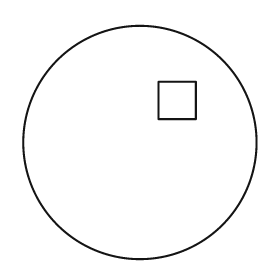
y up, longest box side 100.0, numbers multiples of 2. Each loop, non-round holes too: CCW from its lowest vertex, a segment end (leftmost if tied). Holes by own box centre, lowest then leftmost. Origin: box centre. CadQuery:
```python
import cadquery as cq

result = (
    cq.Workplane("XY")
    .moveTo(0.0, 0.0)
    .circle(50.0)
    .moveTo(8.0, 10.0)
    .lineTo(24.0, 10.0)
    .lineTo(24.0, 26.0)
    .lineTo(8.0, 26.0)
    .close()
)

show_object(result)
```